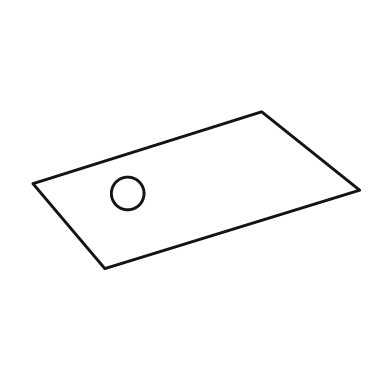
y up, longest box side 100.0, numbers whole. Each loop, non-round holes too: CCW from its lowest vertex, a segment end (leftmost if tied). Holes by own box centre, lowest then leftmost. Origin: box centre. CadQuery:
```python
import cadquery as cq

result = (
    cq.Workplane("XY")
    .moveTo(-28.0, -24.0)
    .lineTo(50.0, 0.0)
    .lineTo(20.0, 24.0)
    .lineTo(-50.0, 2.0)
    .close()
    .moveTo(-21.0, -1.0)
    .circle(5.0)
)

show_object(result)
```